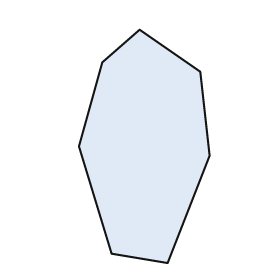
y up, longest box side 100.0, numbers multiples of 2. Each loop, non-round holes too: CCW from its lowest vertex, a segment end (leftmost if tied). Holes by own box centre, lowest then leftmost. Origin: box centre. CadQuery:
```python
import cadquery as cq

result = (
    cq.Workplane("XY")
    .moveTo(10.0, -50.0)
    .lineTo(28.0, -4.0)
    .lineTo(24.0, 32.0)
    .lineTo(-2.0, 50.0)
    .lineTo(-18.0, 36.0)
    .lineTo(-28.0, 0.0)
    .lineTo(-14.0, -46.0)
    .close()
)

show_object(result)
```